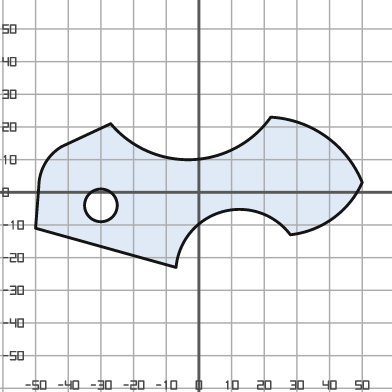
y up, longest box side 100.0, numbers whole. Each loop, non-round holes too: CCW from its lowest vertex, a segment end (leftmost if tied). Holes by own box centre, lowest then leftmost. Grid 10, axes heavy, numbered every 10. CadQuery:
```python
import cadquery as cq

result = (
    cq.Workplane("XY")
    .moveTo(-7.0, -23.0)
    .threePointArc((7.0, -6.0), (28.0, -13.0))
    .threePointArc((41.0, -8.0), (50.0, 3.0))
    .threePointArc((39.0, 17.0), (22.0, 23.0))
    .threePointArc((-2.0, 10.0), (-27.0, 21.0))
    .lineTo(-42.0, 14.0)
    .threePointArc((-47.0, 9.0), (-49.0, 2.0))
    .lineTo(-50.0, -11.0)
    .close()
    .moveTo(-30.0, -4.0)
    .circle(5.0)
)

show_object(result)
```